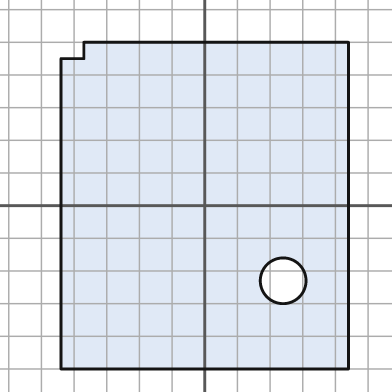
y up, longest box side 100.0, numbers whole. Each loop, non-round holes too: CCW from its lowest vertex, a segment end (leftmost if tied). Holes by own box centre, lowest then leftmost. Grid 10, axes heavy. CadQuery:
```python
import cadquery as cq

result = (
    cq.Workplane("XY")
    .moveTo(-44.0, -50.0)
    .lineTo(44.0, -50.0)
    .lineTo(44.0, 50.0)
    .lineTo(-37.0, 50.0)
    .lineTo(-37.0, 45.0)
    .lineTo(-44.0, 45.0)
    .close()
    .moveTo(24.0, -23.0)
    .circle(7.0)
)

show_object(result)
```